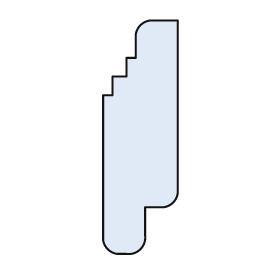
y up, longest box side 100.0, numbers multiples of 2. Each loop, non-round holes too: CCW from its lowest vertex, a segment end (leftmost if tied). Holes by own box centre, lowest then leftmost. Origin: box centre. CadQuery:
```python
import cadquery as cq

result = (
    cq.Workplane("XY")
    .moveTo(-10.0, -50.0)
    .lineTo(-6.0, -50.0)
    .threePointArc((0.0, -48.0), (2.0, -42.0))
    .lineTo(2.0, -30.0)
    .lineTo(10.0, -30.0)
    .threePointArc((14.0, -28.0), (16.0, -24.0))
    .lineTo(16.0, 50.0)
    .lineTo(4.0, 50.0)
    .threePointArc((0.0, 48.0), (-2.0, 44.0))
    .lineTo(-2.0, 34.0)
    .lineTo(-6.0, 34.0)
    .lineTo(-6.0, 26.0)
    .lineTo(-12.0, 26.0)
    .lineTo(-12.0, 18.0)
    .lineTo(-16.0, 18.0)
    .lineTo(-16.0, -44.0)
    .threePointArc((-14.0, -48.0), (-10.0, -50.0))
    .close()
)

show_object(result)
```